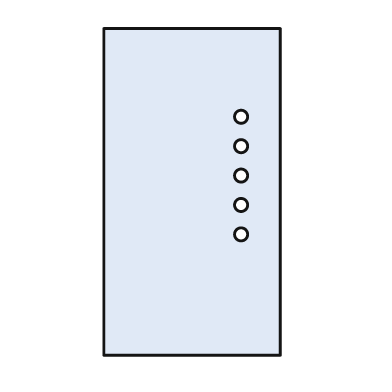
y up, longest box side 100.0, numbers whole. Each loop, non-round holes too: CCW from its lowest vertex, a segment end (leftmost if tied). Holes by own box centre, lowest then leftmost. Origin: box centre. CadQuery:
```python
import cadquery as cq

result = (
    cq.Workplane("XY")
    .moveTo(-27.0, -50.0)
    .lineTo(27.0, -50.0)
    .lineTo(27.0, 50.0)
    .lineTo(-27.0, 50.0)
    .close()
    .moveTo(15.0, -13.0)
    .circle(2.0)
    .moveTo(15.0, -4.0)
    .circle(2.0)
    .moveTo(15.0, 5.0)
    .circle(2.0)
    .moveTo(15.0, 14.0)
    .circle(2.0)
    .moveTo(15.0, 23.0)
    .circle(2.0)
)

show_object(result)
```